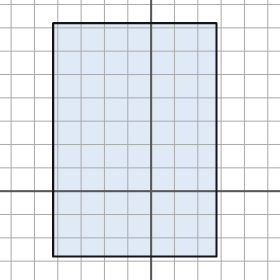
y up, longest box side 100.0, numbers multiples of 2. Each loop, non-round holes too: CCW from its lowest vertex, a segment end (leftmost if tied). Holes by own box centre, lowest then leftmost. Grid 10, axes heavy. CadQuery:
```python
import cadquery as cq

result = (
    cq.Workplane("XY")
    .moveTo(-42.0, -28.0)
    .lineTo(28.0, -28.0)
    .lineTo(28.0, 72.0)
    .lineTo(-42.0, 72.0)
    .close()
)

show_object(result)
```